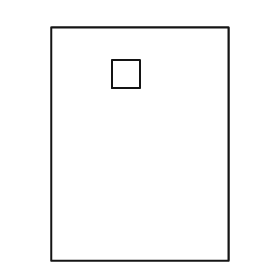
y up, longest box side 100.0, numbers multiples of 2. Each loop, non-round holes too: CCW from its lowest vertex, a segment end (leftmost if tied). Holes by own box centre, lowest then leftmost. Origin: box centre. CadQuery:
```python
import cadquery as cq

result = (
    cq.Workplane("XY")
    .moveTo(-38.0, -50.0)
    .lineTo(38.0, -50.0)
    .lineTo(38.0, 50.0)
    .lineTo(-38.0, 50.0)
    .close()
    .moveTo(-12.0, 24.0)
    .lineTo(0.0, 24.0)
    .lineTo(0.0, 36.0)
    .lineTo(-12.0, 36.0)
    .close()
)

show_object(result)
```